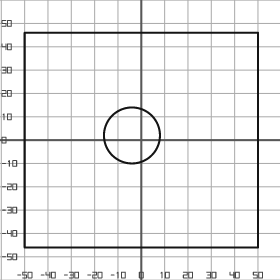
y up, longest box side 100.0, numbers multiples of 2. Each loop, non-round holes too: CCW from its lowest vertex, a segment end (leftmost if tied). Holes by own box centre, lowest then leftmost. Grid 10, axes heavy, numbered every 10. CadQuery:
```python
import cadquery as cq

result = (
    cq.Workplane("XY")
    .moveTo(-50.0, -46.0)
    .lineTo(50.0, -46.0)
    .lineTo(50.0, 46.0)
    .lineTo(-50.0, 46.0)
    .close()
    .moveTo(-4.0, 2.0)
    .circle(12.0)
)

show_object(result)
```